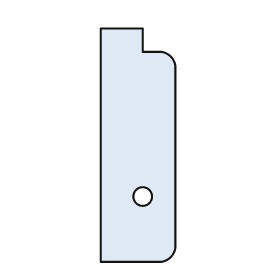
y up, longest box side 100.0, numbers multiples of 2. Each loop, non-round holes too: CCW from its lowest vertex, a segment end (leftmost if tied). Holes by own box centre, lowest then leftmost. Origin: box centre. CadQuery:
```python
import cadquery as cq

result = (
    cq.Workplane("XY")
    .moveTo(-16.0, -50.0)
    .lineTo(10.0, -50.0)
    .threePointArc((14.0, -48.0), (16.0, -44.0))
    .lineTo(16.0, 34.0)
    .threePointArc((14.0, 38.0), (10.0, 40.0))
    .lineTo(2.0, 40.0)
    .lineTo(2.0, 50.0)
    .lineTo(-16.0, 50.0)
    .close()
    .moveTo(2.0, -22.0)
    .circle(4.0)
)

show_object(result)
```